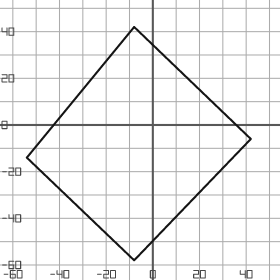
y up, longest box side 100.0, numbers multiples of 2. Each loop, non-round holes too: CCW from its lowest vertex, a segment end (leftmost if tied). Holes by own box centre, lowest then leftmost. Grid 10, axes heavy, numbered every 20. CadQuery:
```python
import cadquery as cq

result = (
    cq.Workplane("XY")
    .moveTo(-8.0, -58.0)
    .lineTo(42.0, -6.0)
    .lineTo(-8.0, 42.0)
    .lineTo(-54.0, -14.0)
    .close()
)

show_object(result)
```